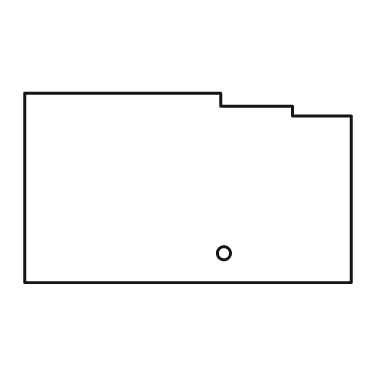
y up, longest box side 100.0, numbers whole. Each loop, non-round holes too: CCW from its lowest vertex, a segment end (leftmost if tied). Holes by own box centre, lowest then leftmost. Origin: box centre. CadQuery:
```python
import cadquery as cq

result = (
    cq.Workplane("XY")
    .moveTo(-50.0, -29.0)
    .lineTo(50.0, -29.0)
    .lineTo(50.0, 22.0)
    .lineTo(32.0, 22.0)
    .lineTo(32.0, 25.0)
    .lineTo(10.0, 25.0)
    .lineTo(10.0, 29.0)
    .lineTo(-50.0, 29.0)
    .close()
    .moveTo(11.0, -20.0)
    .circle(2.0)
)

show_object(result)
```